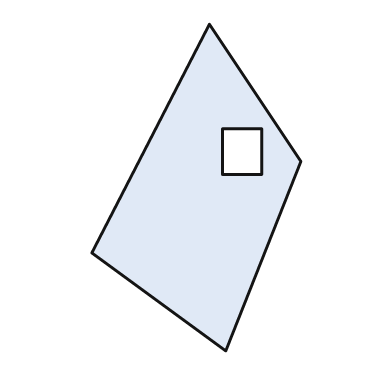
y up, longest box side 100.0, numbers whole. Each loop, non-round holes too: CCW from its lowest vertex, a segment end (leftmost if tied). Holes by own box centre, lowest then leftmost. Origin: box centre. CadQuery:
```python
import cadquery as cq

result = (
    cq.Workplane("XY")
    .moveTo(9.0, -50.0)
    .lineTo(32.0, 8.0)
    .lineTo(4.0, 50.0)
    .lineTo(-32.0, -20.0)
    .close()
    .moveTo(8.0, 4.0)
    .lineTo(20.0, 4.0)
    .lineTo(20.0, 18.0)
    .lineTo(8.0, 18.0)
    .close()
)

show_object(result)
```